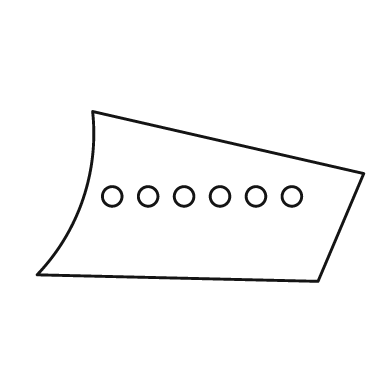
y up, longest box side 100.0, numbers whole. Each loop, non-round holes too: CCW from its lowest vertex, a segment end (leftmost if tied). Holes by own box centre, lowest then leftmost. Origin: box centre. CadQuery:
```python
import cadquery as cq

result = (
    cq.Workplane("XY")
    .moveTo(36.0, -26.0)
    .lineTo(50.0, 7.0)
    .lineTo(-33.0, 26.0)
    .threePointArc((-36.0, -1.0), (-50.0, -24.0))
    .close()
    .moveTo(-27.0, 0.0)
    .circle(3.0)
    .moveTo(-16.0, 0.0)
    .circle(3.0)
    .moveTo(-5.0, 0.0)
    .circle(3.0)
    .moveTo(6.0, 0.0)
    .circle(3.0)
    .moveTo(17.0, 0.0)
    .circle(3.0)
    .moveTo(28.0, 0.0)
    .circle(3.0)
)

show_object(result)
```